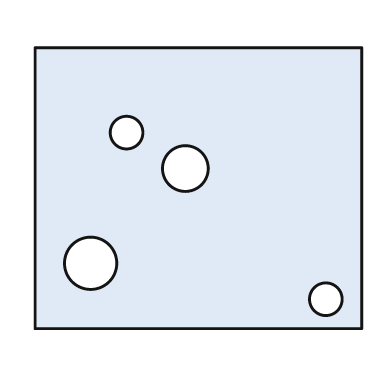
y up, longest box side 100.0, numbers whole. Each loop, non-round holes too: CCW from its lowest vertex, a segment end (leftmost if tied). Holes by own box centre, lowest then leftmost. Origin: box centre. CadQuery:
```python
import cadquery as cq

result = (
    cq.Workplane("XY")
    .moveTo(-50.0, -43.0)
    .lineTo(50.0, -43.0)
    .lineTo(50.0, 43.0)
    .lineTo(-50.0, 43.0)
    .close()
    .moveTo(39.0, -34.0)
    .circle(5.0)
    .moveTo(-33.0, -23.0)
    .circle(8.0)
    .moveTo(-4.0, 6.0)
    .circle(7.0)
    .moveTo(-22.0, 17.0)
    .circle(5.0)
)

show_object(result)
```